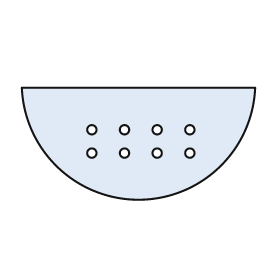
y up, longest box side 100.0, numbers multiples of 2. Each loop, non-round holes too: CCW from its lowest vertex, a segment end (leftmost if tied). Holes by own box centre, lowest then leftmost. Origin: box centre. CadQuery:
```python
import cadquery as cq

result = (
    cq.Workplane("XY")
    .moveTo(-50.0, 24.0)
    .threePointArc((0.0, -24.0), (50.0, 24.0))
    .close()
    .moveTo(-20.0, -4.0)
    .circle(2.0)
    .moveTo(-6.0, -4.0)
    .circle(2.0)
    .moveTo(8.0, -4.0)
    .circle(2.0)
    .moveTo(22.0, -4.0)
    .circle(2.0)
    .moveTo(-20.0, 6.0)
    .circle(2.0)
    .moveTo(-6.0, 6.0)
    .circle(2.0)
    .moveTo(8.0, 6.0)
    .circle(2.0)
    .moveTo(22.0, 6.0)
    .circle(2.0)
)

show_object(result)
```